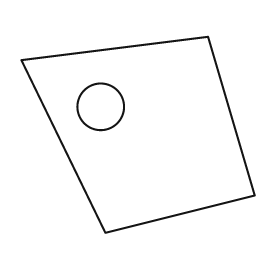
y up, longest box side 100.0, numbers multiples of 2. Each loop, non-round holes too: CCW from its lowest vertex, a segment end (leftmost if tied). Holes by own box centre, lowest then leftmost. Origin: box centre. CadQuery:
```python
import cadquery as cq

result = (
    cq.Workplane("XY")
    .moveTo(-14.0, -42.0)
    .lineTo(50.0, -26.0)
    .lineTo(30.0, 42.0)
    .lineTo(-50.0, 32.0)
    .close()
    .moveTo(-16.0, 12.0)
    .circle(10.0)
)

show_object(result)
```